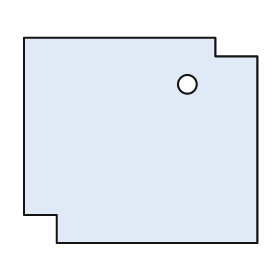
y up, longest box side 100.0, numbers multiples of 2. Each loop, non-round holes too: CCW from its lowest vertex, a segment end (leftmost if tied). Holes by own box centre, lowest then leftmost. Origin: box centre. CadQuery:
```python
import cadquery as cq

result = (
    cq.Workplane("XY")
    .moveTo(-36.0, -44.0)
    .lineTo(50.0, -44.0)
    .lineTo(50.0, 36.0)
    .lineTo(32.0, 36.0)
    .lineTo(32.0, 44.0)
    .lineTo(-50.0, 44.0)
    .lineTo(-50.0, -32.0)
    .lineTo(-36.0, -32.0)
    .close()
    .moveTo(20.0, 24.0)
    .circle(4.0)
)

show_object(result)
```